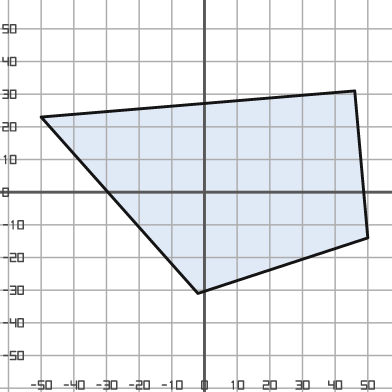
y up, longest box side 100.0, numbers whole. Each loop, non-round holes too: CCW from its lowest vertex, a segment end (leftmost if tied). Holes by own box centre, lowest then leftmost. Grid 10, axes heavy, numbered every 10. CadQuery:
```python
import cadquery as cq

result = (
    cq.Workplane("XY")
    .moveTo(-2.0, -31.0)
    .lineTo(50.0, -14.0)
    .lineTo(46.0, 31.0)
    .lineTo(-50.0, 23.0)
    .close()
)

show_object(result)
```